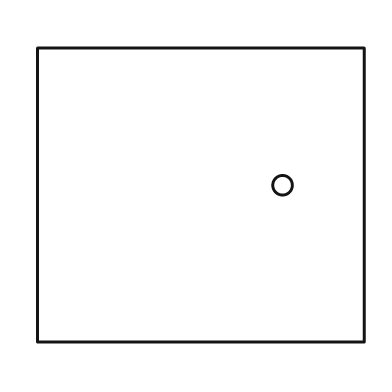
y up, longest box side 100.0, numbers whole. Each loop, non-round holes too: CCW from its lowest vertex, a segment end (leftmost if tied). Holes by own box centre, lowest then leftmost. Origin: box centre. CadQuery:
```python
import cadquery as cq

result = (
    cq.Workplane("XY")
    .moveTo(-50.0, -45.0)
    .lineTo(50.0, -45.0)
    .lineTo(50.0, 45.0)
    .lineTo(-50.0, 45.0)
    .close()
    .moveTo(25.0, 3.0)
    .circle(3.0)
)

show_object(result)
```